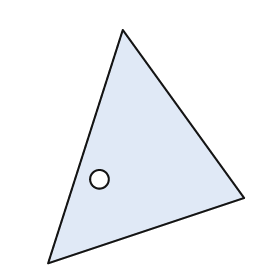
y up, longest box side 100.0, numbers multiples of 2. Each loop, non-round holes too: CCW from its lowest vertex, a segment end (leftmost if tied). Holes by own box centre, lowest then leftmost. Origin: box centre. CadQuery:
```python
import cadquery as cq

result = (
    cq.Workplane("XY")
    .moveTo(-42.0, -50.0)
    .lineTo(42.0, -22.0)
    .lineTo(-10.0, 50.0)
    .close()
    .moveTo(-20.0, -14.0)
    .circle(4.0)
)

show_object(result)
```